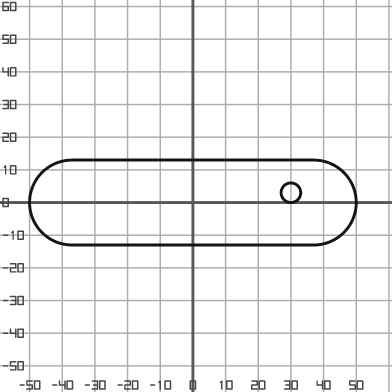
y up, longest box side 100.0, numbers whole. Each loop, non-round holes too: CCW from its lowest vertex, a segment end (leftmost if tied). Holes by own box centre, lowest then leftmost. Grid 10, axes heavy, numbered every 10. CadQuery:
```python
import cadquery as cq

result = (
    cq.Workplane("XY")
    .moveTo(-37.0, -13.0)
    .lineTo(37.0, -13.0)
    .threePointArc((50.0, 0.0), (37.0, 13.0))
    .lineTo(-37.0, 13.0)
    .threePointArc((-50.0, 0.0), (-37.0, -13.0))
    .close()
    .moveTo(30.0, 3.0)
    .circle(3.0)
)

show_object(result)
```